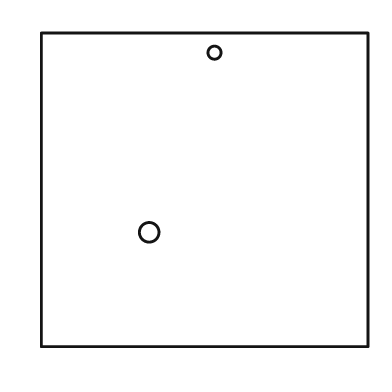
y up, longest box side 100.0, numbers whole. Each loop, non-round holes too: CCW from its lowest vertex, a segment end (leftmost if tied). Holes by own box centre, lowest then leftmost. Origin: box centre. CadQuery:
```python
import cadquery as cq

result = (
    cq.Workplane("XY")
    .moveTo(-50.0, -48.0)
    .lineTo(50.0, -48.0)
    .lineTo(50.0, 48.0)
    .lineTo(-50.0, 48.0)
    .close()
    .moveTo(-17.0, -13.0)
    .circle(3.0)
    .moveTo(3.0, 42.0)
    .circle(2.0)
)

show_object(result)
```